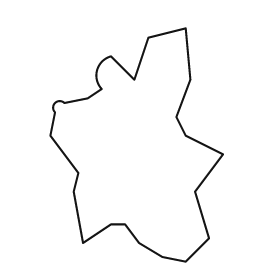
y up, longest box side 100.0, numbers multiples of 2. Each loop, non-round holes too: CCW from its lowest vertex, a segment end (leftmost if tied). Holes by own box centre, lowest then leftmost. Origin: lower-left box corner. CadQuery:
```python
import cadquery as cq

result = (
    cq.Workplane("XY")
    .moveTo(58.0, 0.0)
    .lineTo(68.0, 10.0)
    .lineTo(62.0, 30.0)
    .lineTo(74.0, 46.0)
    .lineTo(58.0, 54.0)
    .lineTo(54.0, 62.0)
    .lineTo(60.0, 78.0)
    .lineTo(58.0, 100.0)
    .lineTo(42.0, 96.0)
    .lineTo(36.0, 78.0)
    .lineTo(26.0, 88.0)
    .threePointArc((20.0, 82.0), (22.0, 74.0))
    .lineTo(16.0, 70.0)
    .lineTo(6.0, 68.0)
    .threePointArc((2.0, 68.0), (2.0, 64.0))
    .lineTo(0.0, 54.0)
    .lineTo(12.0, 38.0)
    .lineTo(10.0, 30.0)
    .lineTo(14.0, 8.0)
    .lineTo(26.0, 16.0)
    .lineTo(32.0, 16.0)
    .lineTo(38.0, 8.0)
    .lineTo(48.0, 2.0)
    .close()
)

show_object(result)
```